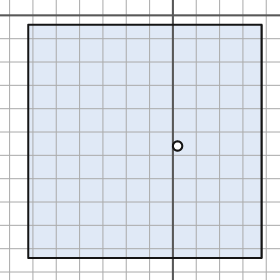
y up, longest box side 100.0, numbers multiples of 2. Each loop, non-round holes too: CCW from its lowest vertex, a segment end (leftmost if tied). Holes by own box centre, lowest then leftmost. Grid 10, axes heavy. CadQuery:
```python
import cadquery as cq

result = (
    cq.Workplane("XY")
    .moveTo(-62.0, -104.0)
    .lineTo(38.0, -104.0)
    .lineTo(38.0, -4.0)
    .lineTo(-62.0, -4.0)
    .close()
    .moveTo(2.0, -56.0)
    .circle(2.0)
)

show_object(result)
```